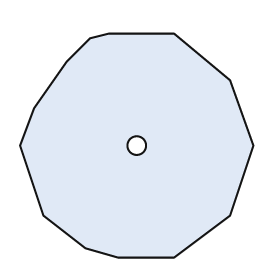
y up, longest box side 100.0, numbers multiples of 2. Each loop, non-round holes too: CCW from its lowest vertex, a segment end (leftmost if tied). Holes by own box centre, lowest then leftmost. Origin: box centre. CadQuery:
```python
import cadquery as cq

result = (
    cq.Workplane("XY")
    .moveTo(-8.0, -48.0)
    .lineTo(16.0, -48.0)
    .lineTo(40.0, -30.0)
    .lineTo(50.0, 0.0)
    .lineTo(40.0, 28.0)
    .lineTo(16.0, 48.0)
    .lineTo(-12.0, 48.0)
    .lineTo(-20.0, 46.0)
    .lineTo(-30.0, 36.0)
    .lineTo(-44.0, 16.0)
    .lineTo(-50.0, 0.0)
    .lineTo(-40.0, -30.0)
    .lineTo(-22.0, -44.0)
    .close()
    .moveTo(0.0, 0.0)
    .circle(4.0)
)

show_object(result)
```